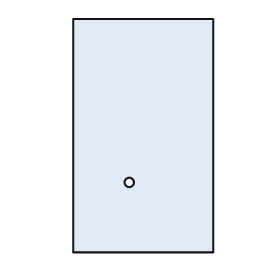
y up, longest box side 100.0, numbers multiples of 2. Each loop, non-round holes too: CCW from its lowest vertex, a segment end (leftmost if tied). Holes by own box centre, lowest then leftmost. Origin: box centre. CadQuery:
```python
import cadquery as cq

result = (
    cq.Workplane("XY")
    .moveTo(-30.0, -50.0)
    .lineTo(30.0, -50.0)
    .lineTo(30.0, 50.0)
    .lineTo(-30.0, 50.0)
    .close()
    .moveTo(-6.0, -20.0)
    .circle(2.0)
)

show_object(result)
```